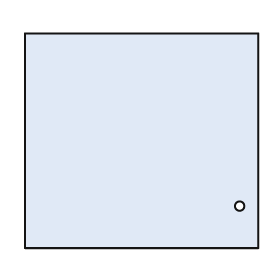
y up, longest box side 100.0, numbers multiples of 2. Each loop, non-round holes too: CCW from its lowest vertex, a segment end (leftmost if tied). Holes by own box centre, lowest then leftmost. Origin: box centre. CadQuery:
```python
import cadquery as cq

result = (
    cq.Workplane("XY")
    .moveTo(-50.0, -46.0)
    .lineTo(50.0, -46.0)
    .lineTo(50.0, 46.0)
    .lineTo(-50.0, 46.0)
    .close()
    .moveTo(42.0, -28.0)
    .circle(2.0)
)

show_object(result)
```